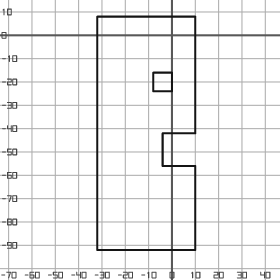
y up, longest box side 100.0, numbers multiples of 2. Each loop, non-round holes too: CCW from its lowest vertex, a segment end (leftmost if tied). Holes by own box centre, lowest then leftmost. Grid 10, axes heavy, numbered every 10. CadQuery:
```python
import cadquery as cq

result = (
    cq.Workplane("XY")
    .moveTo(-32.0, -92.0)
    .lineTo(10.0, -92.0)
    .lineTo(10.0, -56.0)
    .lineTo(-4.0, -56.0)
    .lineTo(-4.0, -42.0)
    .lineTo(10.0, -42.0)
    .lineTo(10.0, 8.0)
    .lineTo(-32.0, 8.0)
    .close()
    .moveTo(-8.0, -24.0)
    .lineTo(0.0, -24.0)
    .lineTo(0.0, -16.0)
    .lineTo(-8.0, -16.0)
    .close()
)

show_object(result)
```